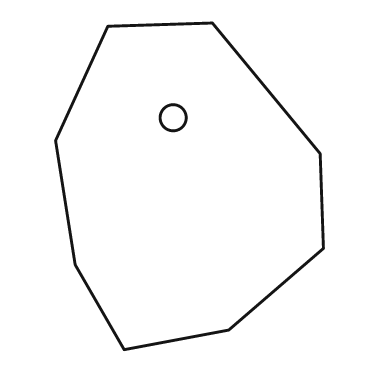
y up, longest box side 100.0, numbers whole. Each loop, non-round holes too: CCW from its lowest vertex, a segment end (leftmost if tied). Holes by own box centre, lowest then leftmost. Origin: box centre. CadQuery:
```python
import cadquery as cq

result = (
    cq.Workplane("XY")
    .moveTo(-20.0, -50.0)
    .lineTo(12.0, -44.0)
    .lineTo(41.0, -19.0)
    .lineTo(40.0, 10.0)
    .lineTo(7.0, 50.0)
    .lineTo(-25.0, 49.0)
    .lineTo(-41.0, 14.0)
    .lineTo(-35.0, -24.0)
    .close()
    .moveTo(-5.0, 21.0)
    .circle(4.0)
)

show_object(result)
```